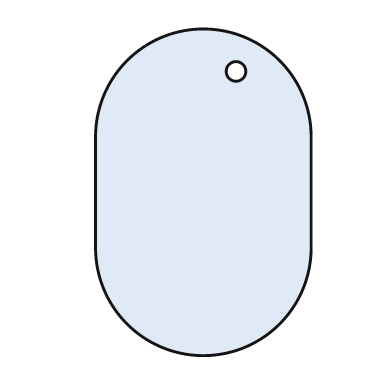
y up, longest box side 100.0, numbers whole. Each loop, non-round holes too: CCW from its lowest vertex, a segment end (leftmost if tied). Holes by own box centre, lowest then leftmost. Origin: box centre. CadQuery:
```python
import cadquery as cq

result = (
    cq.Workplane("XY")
    .moveTo(-33.0, -17.0)
    .threePointArc((0.0, -50.0), (33.0, -17.0))
    .lineTo(33.0, 17.0)
    .threePointArc((0.0, 50.0), (-33.0, 17.0))
    .close()
    .moveTo(10.0, 37.0)
    .circle(3.0)
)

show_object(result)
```